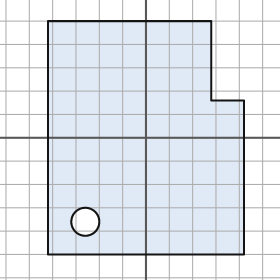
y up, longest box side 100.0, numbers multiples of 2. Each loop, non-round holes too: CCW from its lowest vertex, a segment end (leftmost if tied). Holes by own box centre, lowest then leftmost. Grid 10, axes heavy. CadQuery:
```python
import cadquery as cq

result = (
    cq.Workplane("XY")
    .moveTo(-42.0, -50.0)
    .lineTo(42.0, -50.0)
    .lineTo(42.0, 16.0)
    .lineTo(28.0, 16.0)
    .lineTo(28.0, 50.0)
    .lineTo(-42.0, 50.0)
    .close()
    .moveTo(-26.0, -36.0)
    .circle(6.0)
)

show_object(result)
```